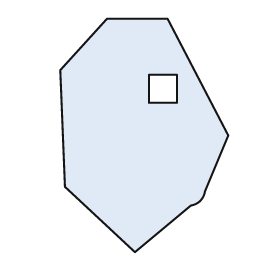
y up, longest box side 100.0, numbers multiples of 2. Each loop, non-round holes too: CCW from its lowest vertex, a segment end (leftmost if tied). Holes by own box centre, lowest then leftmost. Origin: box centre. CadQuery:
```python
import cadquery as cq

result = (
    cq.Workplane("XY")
    .moveTo(-4.0, -50.0)
    .lineTo(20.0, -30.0)
    .threePointArc((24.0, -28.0), (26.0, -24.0))
    .lineTo(36.0, 0.0)
    .lineTo(10.0, 50.0)
    .lineTo(-16.0, 50.0)
    .lineTo(-36.0, 28.0)
    .lineTo(-34.0, -22.0)
    .close()
    .moveTo(2.0, 14.0)
    .lineTo(14.0, 14.0)
    .lineTo(14.0, 26.0)
    .lineTo(2.0, 26.0)
    .close()
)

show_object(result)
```